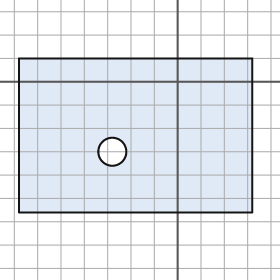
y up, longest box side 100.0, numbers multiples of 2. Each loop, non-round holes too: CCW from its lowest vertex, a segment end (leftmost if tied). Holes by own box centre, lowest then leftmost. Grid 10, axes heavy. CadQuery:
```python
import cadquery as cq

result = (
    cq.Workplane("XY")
    .moveTo(-68.0, -56.0)
    .lineTo(32.0, -56.0)
    .lineTo(32.0, 10.0)
    .lineTo(-68.0, 10.0)
    .close()
    .moveTo(-28.0, -30.0)
    .circle(6.0)
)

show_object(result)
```